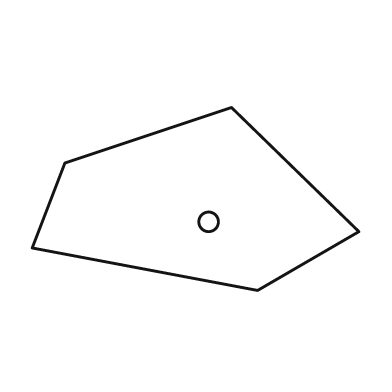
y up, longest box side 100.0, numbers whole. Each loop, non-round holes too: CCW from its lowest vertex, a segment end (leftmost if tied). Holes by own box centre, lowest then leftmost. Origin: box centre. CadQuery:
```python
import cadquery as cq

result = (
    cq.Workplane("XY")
    .moveTo(19.0, -28.0)
    .lineTo(50.0, -10.0)
    .lineTo(11.0, 28.0)
    .lineTo(-40.0, 11.0)
    .lineTo(-50.0, -15.0)
    .close()
    .moveTo(4.0, -7.0)
    .circle(3.0)
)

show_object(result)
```